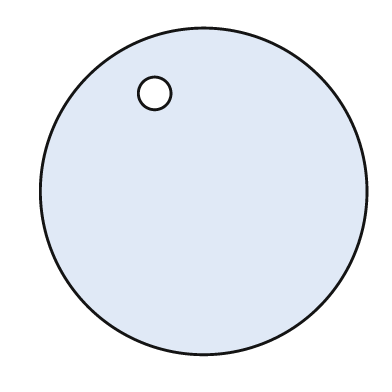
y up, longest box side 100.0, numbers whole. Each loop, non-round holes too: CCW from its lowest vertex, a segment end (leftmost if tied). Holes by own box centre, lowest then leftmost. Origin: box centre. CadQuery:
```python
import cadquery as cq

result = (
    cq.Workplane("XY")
    .moveTo(0.0, 0.0)
    .circle(50.0)
    .moveTo(-15.0, 30.0)
    .circle(5.0)
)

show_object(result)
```